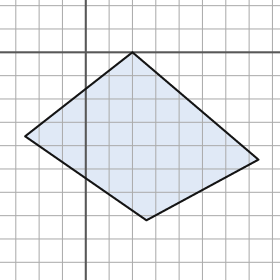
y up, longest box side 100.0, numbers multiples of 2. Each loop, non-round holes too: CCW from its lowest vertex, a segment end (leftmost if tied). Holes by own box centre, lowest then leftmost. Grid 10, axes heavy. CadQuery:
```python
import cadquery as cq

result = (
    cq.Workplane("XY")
    .moveTo(26.0, -72.0)
    .lineTo(74.0, -46.0)
    .lineTo(20.0, 0.0)
    .lineTo(-26.0, -36.0)
    .close()
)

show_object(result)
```